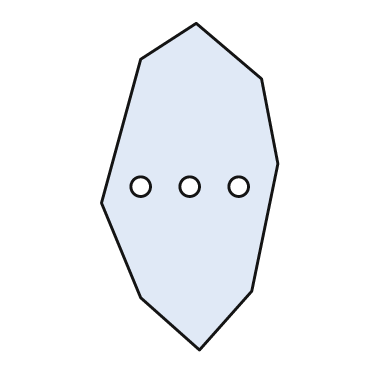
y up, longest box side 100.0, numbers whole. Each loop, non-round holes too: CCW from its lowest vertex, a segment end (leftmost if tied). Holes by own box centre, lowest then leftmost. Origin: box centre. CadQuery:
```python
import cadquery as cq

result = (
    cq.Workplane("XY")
    .moveTo(3.0, -50.0)
    .lineTo(19.0, -32.0)
    .lineTo(27.0, 7.0)
    .lineTo(22.0, 33.0)
    .lineTo(2.0, 50.0)
    .lineTo(-15.0, 39.0)
    .lineTo(-27.0, -5.0)
    .lineTo(-15.0, -34.0)
    .close()
    .moveTo(-15.0, 0.0)
    .circle(3.0)
    .moveTo(0.0, 0.0)
    .circle(3.0)
    .moveTo(15.0, 0.0)
    .circle(3.0)
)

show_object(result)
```